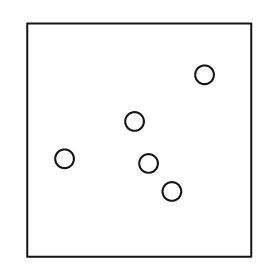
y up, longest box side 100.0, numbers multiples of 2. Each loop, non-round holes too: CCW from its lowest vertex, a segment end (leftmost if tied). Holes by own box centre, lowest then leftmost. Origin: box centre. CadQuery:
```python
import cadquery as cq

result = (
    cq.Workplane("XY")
    .moveTo(-48.0, -50.0)
    .lineTo(48.0, -50.0)
    .lineTo(48.0, 50.0)
    .lineTo(-48.0, 50.0)
    .close()
    .moveTo(14.0, -22.0)
    .circle(4.0)
    .moveTo(4.0, -10.0)
    .circle(4.0)
    .moveTo(-32.0, -8.0)
    .circle(4.0)
    .moveTo(-2.0, 8.0)
    .circle(4.0)
    .moveTo(28.0, 28.0)
    .circle(4.0)
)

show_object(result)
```